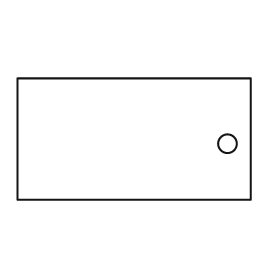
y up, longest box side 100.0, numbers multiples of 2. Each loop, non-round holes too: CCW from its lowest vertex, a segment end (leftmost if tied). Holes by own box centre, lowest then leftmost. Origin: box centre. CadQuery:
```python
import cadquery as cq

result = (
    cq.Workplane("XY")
    .moveTo(-50.0, -26.0)
    .lineTo(50.0, -26.0)
    .lineTo(50.0, 26.0)
    .lineTo(-50.0, 26.0)
    .close()
    .moveTo(40.0, -2.0)
    .circle(4.0)
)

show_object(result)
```